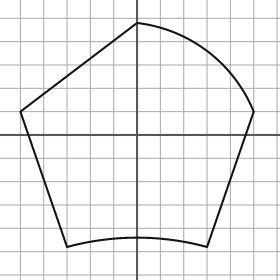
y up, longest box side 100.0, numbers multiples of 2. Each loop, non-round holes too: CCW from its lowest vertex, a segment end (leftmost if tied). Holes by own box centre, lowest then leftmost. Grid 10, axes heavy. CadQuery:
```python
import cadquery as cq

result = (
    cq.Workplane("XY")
    .moveTo(-30.0, -48.0)
    .threePointArc((0.0, -44.0), (30.0, -48.0))
    .lineTo(50.0, 10.0)
    .threePointArc((30.0, 36.0), (0.0, 48.0))
    .lineTo(-50.0, 10.0)
    .close()
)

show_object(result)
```